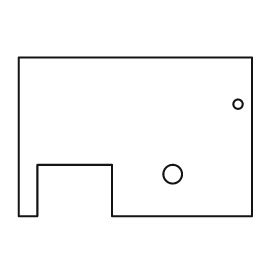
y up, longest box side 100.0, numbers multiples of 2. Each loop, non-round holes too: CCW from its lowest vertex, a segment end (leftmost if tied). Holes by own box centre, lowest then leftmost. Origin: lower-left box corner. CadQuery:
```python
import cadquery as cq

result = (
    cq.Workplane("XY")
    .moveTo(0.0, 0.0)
    .lineTo(8.0, 0.0)
    .lineTo(8.0, 22.0)
    .lineTo(40.0, 22.0)
    .lineTo(40.0, 0.0)
    .lineTo(100.0, 0.0)
    .lineTo(100.0, 68.0)
    .lineTo(0.0, 68.0)
    .close()
    .moveTo(66.0, 18.0)
    .circle(4.0)
    .moveTo(94.0, 48.0)
    .circle(2.0)
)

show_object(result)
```